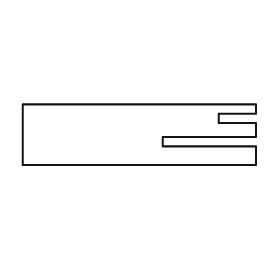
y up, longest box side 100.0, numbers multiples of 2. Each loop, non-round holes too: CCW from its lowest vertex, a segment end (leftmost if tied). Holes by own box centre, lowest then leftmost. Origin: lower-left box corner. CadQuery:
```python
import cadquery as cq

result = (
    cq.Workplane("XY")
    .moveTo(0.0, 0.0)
    .lineTo(100.0, 0.0)
    .lineTo(100.0, 8.0)
    .lineTo(60.0, 8.0)
    .lineTo(60.0, 12.0)
    .lineTo(100.0, 12.0)
    .lineTo(100.0, 18.0)
    .lineTo(84.0, 18.0)
    .lineTo(84.0, 22.0)
    .lineTo(100.0, 22.0)
    .lineTo(100.0, 26.0)
    .lineTo(0.0, 26.0)
    .close()
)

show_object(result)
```